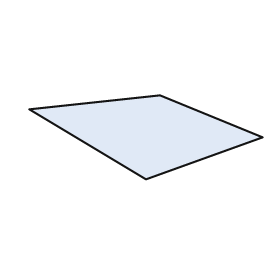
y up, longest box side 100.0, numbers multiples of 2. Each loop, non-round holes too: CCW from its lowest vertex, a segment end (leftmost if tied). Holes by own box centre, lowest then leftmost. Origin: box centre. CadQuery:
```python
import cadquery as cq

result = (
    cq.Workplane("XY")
    .moveTo(0.0, -18.0)
    .lineTo(50.0, 0.0)
    .lineTo(6.0, 18.0)
    .lineTo(-50.0, 12.0)
    .close()
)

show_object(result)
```